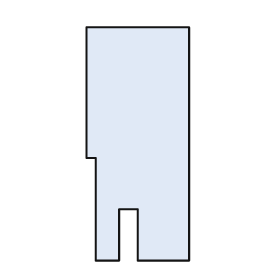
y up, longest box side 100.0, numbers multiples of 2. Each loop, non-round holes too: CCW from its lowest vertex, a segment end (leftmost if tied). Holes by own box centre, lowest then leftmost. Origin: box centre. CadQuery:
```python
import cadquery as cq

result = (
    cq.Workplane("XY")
    .moveTo(-18.0, -50.0)
    .lineTo(-8.0, -50.0)
    .lineTo(-8.0, -28.0)
    .lineTo(0.0, -28.0)
    .lineTo(0.0, -50.0)
    .lineTo(22.0, -50.0)
    .lineTo(22.0, 50.0)
    .lineTo(-22.0, 50.0)
    .lineTo(-22.0, -6.0)
    .lineTo(-18.0, -6.0)
    .close()
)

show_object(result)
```